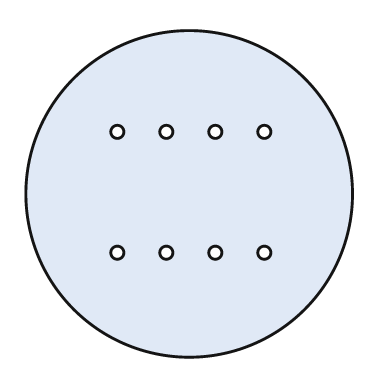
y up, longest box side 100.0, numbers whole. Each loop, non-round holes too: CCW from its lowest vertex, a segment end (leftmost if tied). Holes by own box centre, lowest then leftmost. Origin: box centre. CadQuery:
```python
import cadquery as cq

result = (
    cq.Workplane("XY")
    .moveTo(0.0, 0.0)
    .circle(50.0)
    .moveTo(-22.0, -18.0)
    .circle(2.0)
    .moveTo(-7.0, -18.0)
    .circle(2.0)
    .moveTo(8.0, -18.0)
    .circle(2.0)
    .moveTo(23.0, -18.0)
    .circle(2.0)
    .moveTo(-22.0, 19.0)
    .circle(2.0)
    .moveTo(-7.0, 19.0)
    .circle(2.0)
    .moveTo(8.0, 19.0)
    .circle(2.0)
    .moveTo(23.0, 19.0)
    .circle(2.0)
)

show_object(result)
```